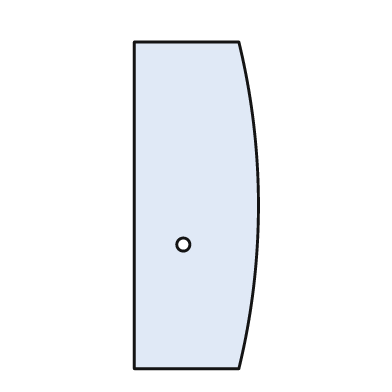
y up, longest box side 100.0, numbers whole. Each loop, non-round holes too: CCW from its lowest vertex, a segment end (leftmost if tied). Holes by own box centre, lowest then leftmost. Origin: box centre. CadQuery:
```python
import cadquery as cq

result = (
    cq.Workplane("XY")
    .moveTo(-19.0, -50.0)
    .lineTo(13.0, -50.0)
    .threePointArc((19.0, 0.0), (13.0, 50.0))
    .lineTo(-19.0, 50.0)
    .close()
    .moveTo(-4.0, -12.0)
    .circle(2.0)
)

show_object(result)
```